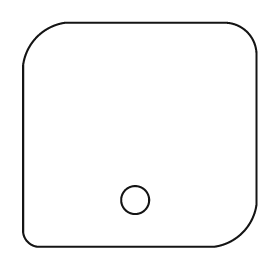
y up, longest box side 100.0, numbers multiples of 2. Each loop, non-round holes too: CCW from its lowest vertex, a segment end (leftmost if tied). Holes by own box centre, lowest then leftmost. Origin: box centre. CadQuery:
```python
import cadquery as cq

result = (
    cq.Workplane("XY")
    .moveTo(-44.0, -48.0)
    .lineTo(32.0, -48.0)
    .threePointArc((44.0, -42.0), (50.0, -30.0))
    .lineTo(50.0, 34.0)
    .threePointArc((46.0, 44.0), (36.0, 48.0))
    .lineTo(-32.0, 48.0)
    .threePointArc((-44.0, 42.0), (-50.0, 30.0))
    .lineTo(-50.0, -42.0)
    .threePointArc((-48.0, -46.0), (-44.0, -48.0))
    .close()
    .moveTo(-2.0, -28.0)
    .circle(6.0)
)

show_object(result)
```